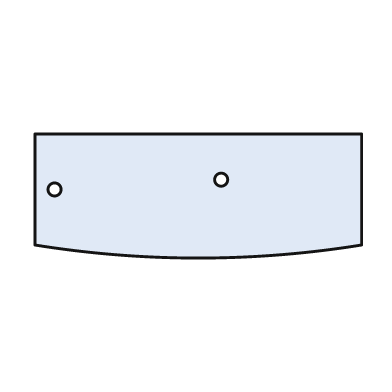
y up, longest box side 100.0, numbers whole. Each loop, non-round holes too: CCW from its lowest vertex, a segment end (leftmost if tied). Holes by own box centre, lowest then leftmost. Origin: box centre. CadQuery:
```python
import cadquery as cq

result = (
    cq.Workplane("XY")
    .moveTo(-50.0, -15.0)
    .threePointArc((0.0, -19.0), (50.0, -15.0))
    .lineTo(50.0, 19.0)
    .lineTo(-50.0, 19.0)
    .close()
    .moveTo(-44.0, 2.0)
    .circle(2.0)
    .moveTo(7.0, 5.0)
    .circle(2.0)
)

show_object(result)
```